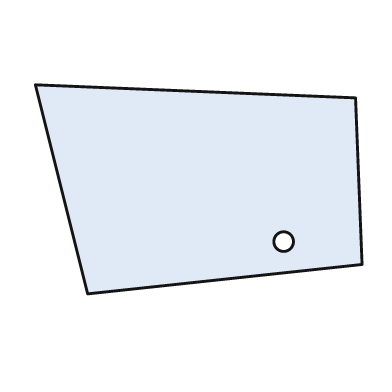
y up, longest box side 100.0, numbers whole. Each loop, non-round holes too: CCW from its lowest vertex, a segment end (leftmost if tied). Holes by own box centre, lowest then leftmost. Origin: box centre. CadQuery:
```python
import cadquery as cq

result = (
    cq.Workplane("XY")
    .moveTo(-34.0, -32.0)
    .lineTo(50.0, -23.0)
    .lineTo(48.0, 28.0)
    .lineTo(-50.0, 32.0)
    .close()
    .moveTo(26.0, -16.0)
    .circle(3.0)
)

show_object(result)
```